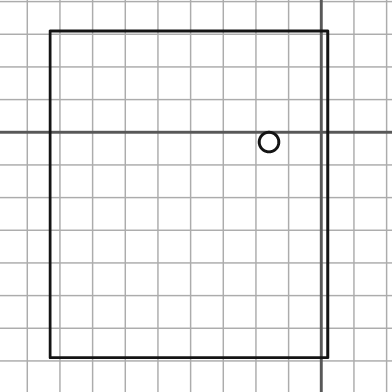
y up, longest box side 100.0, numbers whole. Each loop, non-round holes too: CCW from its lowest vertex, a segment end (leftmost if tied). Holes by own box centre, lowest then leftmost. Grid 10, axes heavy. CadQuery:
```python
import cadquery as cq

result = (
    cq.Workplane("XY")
    .moveTo(-83.0, -69.0)
    .lineTo(2.0, -69.0)
    .lineTo(2.0, 31.0)
    .lineTo(-83.0, 31.0)
    .close()
    .moveTo(-16.0, -3.0)
    .circle(3.0)
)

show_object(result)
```